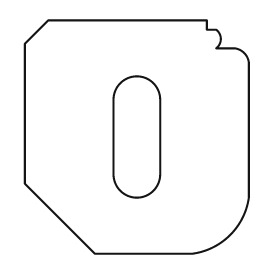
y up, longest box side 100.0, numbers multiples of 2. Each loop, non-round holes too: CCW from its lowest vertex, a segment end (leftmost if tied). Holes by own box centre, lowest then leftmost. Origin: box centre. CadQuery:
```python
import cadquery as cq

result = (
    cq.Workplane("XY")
    .moveTo(-18.0, -50.0)
    .lineTo(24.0, -50.0)
    .threePointArc((40.0, -42.0), (48.0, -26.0))
    .lineTo(48.0, 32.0)
    .threePointArc((46.0, 36.0), (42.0, 38.0))
    .lineTo(34.0, 38.0)
    .threePointArc((36.0, 42.0), (34.0, 46.0))
    .lineTo(30.0, 46.0)
    .lineTo(30.0, 50.0)
    .lineTo(-38.0, 50.0)
    .lineTo(-48.0, 40.0)
    .lineTo(-48.0, -20.0)
    .close()
    .moveTo(-10.0, -16.0)
    .threePointArc((0.0, -26.0), (10.0, -16.0))
    .lineTo(10.0, 16.0)
    .threePointArc((0.0, 26.0), (-10.0, 16.0))
    .close()
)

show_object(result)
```